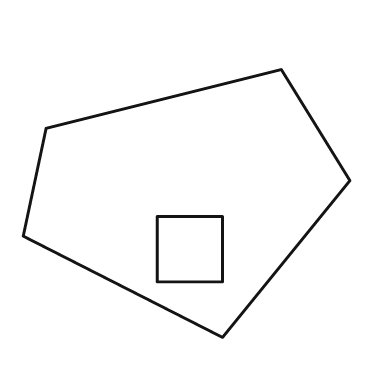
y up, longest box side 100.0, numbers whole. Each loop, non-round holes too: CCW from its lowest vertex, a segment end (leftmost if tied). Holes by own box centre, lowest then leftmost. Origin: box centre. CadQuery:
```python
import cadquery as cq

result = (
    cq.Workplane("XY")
    .moveTo(11.0, -41.0)
    .lineTo(50.0, 7.0)
    .lineTo(29.0, 41.0)
    .lineTo(-43.0, 23.0)
    .lineTo(-50.0, -10.0)
    .close()
    .moveTo(-9.0, -24.0)
    .lineTo(11.0, -24.0)
    .lineTo(11.0, -4.0)
    .lineTo(-9.0, -4.0)
    .close()
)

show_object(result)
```